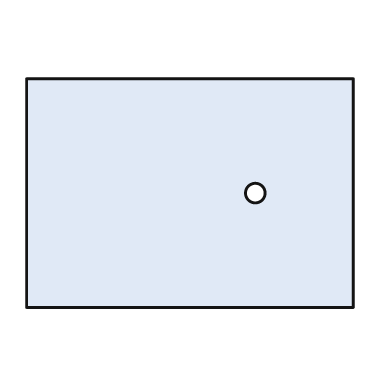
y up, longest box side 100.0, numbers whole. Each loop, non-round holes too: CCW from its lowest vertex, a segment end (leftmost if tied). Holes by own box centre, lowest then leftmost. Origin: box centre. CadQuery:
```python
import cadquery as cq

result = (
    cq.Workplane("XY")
    .moveTo(-50.0, -35.0)
    .lineTo(50.0, -35.0)
    .lineTo(50.0, 35.0)
    .lineTo(-50.0, 35.0)
    .close()
    .moveTo(20.0, 0.0)
    .circle(3.0)
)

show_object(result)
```